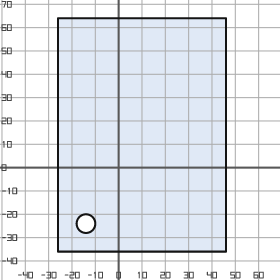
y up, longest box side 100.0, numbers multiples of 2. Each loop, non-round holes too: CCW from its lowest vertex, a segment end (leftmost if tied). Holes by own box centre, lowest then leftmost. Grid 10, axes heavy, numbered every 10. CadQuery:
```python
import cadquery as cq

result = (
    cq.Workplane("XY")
    .moveTo(-26.0, -36.0)
    .lineTo(46.0, -36.0)
    .lineTo(46.0, 64.0)
    .lineTo(-26.0, 64.0)
    .close()
    .moveTo(-14.0, -24.0)
    .circle(4.0)
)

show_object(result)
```